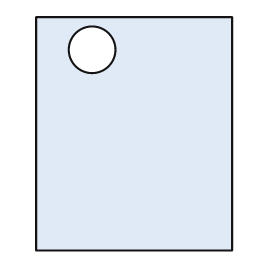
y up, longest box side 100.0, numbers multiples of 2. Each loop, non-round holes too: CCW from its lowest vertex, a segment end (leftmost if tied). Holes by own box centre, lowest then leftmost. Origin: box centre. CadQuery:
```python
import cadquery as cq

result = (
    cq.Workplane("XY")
    .moveTo(-42.0, -50.0)
    .lineTo(42.0, -50.0)
    .lineTo(42.0, 50.0)
    .lineTo(-42.0, 50.0)
    .close()
    .moveTo(-18.0, 36.0)
    .circle(10.0)
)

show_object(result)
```